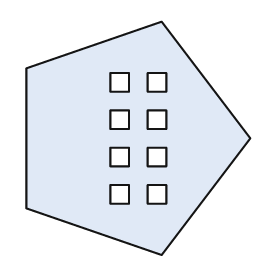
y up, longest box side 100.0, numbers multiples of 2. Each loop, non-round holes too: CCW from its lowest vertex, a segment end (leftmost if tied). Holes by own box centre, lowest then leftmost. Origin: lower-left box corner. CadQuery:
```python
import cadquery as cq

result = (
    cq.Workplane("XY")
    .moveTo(58.0, 0.0)
    .lineTo(96.0, 50.0)
    .lineTo(58.0, 100.0)
    .lineTo(0.0, 80.0)
    .lineTo(0.0, 20.0)
    .close()
    .moveTo(36.0, 22.0)
    .lineTo(44.0, 22.0)
    .lineTo(44.0, 30.0)
    .lineTo(36.0, 30.0)
    .close()
    .moveTo(52.0, 22.0)
    .lineTo(60.0, 22.0)
    .lineTo(60.0, 30.0)
    .lineTo(52.0, 30.0)
    .close()
    .moveTo(36.0, 38.0)
    .lineTo(44.0, 38.0)
    .lineTo(44.0, 46.0)
    .lineTo(36.0, 46.0)
    .close()
    .moveTo(52.0, 38.0)
    .lineTo(60.0, 38.0)
    .lineTo(60.0, 46.0)
    .lineTo(52.0, 46.0)
    .close()
    .moveTo(36.0, 54.0)
    .lineTo(44.0, 54.0)
    .lineTo(44.0, 62.0)
    .lineTo(36.0, 62.0)
    .close()
    .moveTo(52.0, 54.0)
    .lineTo(60.0, 54.0)
    .lineTo(60.0, 62.0)
    .lineTo(52.0, 62.0)
    .close()
    .moveTo(36.0, 70.0)
    .lineTo(44.0, 70.0)
    .lineTo(44.0, 78.0)
    .lineTo(36.0, 78.0)
    .close()
    .moveTo(52.0, 70.0)
    .lineTo(60.0, 70.0)
    .lineTo(60.0, 78.0)
    .lineTo(52.0, 78.0)
    .close()
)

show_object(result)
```